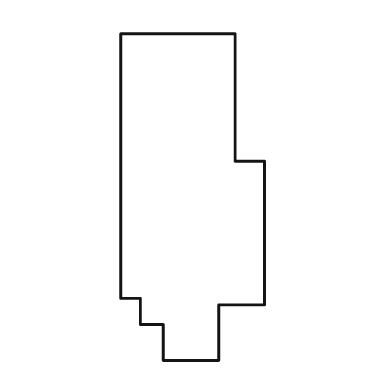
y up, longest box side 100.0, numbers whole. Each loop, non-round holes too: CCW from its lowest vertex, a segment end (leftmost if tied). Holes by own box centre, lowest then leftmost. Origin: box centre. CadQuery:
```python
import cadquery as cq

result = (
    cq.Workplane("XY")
    .moveTo(-9.0, -50.0)
    .lineTo(8.0, -50.0)
    .lineTo(8.0, -33.0)
    .lineTo(22.0, -33.0)
    .lineTo(22.0, 11.0)
    .lineTo(13.0, 11.0)
    .lineTo(13.0, 50.0)
    .lineTo(-22.0, 50.0)
    .lineTo(-22.0, -31.0)
    .lineTo(-16.0, -31.0)
    .lineTo(-16.0, -39.0)
    .lineTo(-9.0, -39.0)
    .close()
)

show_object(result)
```